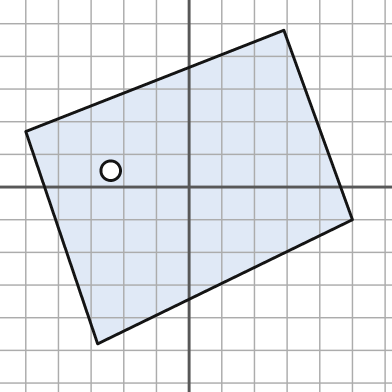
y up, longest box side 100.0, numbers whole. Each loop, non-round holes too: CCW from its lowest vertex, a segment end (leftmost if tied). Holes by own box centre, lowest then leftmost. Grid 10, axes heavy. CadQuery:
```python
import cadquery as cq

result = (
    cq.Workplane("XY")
    .moveTo(-28.0, -48.0)
    .lineTo(50.0, -10.0)
    .lineTo(29.0, 48.0)
    .lineTo(-50.0, 17.0)
    .close()
    .moveTo(-24.0, 5.0)
    .circle(3.0)
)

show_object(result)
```